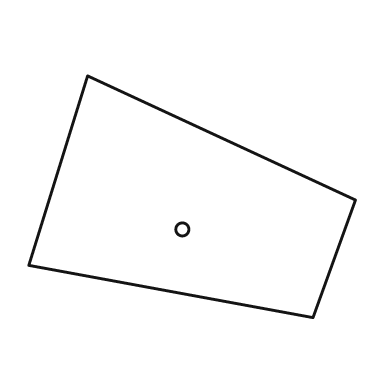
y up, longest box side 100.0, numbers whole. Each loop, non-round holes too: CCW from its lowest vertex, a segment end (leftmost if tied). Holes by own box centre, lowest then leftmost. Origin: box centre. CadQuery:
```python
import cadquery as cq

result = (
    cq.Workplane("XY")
    .moveTo(37.0, -37.0)
    .lineTo(50.0, -1.0)
    .lineTo(-32.0, 37.0)
    .lineTo(-50.0, -21.0)
    .close()
    .moveTo(-3.0, -10.0)
    .circle(2.0)
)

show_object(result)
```